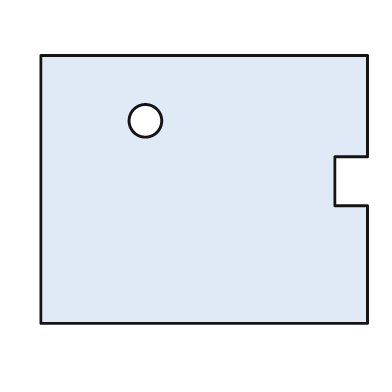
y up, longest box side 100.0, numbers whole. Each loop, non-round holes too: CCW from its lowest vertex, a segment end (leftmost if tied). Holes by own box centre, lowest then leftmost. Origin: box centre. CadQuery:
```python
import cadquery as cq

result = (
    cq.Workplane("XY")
    .moveTo(-50.0, -41.0)
    .lineTo(50.0, -41.0)
    .lineTo(50.0, -5.0)
    .lineTo(40.0, -5.0)
    .lineTo(40.0, 10.0)
    .lineTo(50.0, 10.0)
    .lineTo(50.0, 41.0)
    .lineTo(-50.0, 41.0)
    .close()
    .moveTo(-18.0, 21.0)
    .circle(5.0)
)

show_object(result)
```